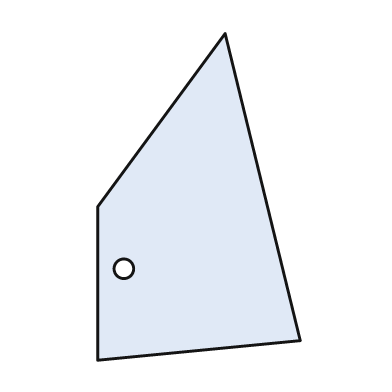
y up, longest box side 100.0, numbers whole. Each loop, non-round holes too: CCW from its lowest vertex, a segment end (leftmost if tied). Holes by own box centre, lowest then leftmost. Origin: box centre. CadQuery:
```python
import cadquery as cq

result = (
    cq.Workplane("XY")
    .moveTo(-31.0, -50.0)
    .lineTo(31.0, -44.0)
    .lineTo(8.0, 50.0)
    .lineTo(-31.0, -3.0)
    .close()
    .moveTo(-23.0, -22.0)
    .circle(3.0)
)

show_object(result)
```